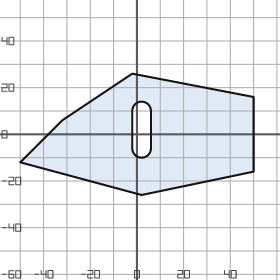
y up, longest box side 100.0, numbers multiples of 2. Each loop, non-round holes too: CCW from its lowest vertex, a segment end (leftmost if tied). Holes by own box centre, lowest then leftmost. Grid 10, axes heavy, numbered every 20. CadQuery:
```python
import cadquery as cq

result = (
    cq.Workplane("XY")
    .moveTo(2.0, -26.0)
    .lineTo(50.0, -16.0)
    .lineTo(50.0, 16.0)
    .lineTo(-2.0, 26.0)
    .lineTo(-32.0, 6.0)
    .lineTo(-50.0, -12.0)
    .close()
    .moveTo(-2.0, -6.0)
    .threePointArc((2.0, -10.0), (6.0, -6.0))
    .lineTo(6.0, 10.0)
    .threePointArc((2.0, 14.0), (-2.0, 10.0))
    .close()
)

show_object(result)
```